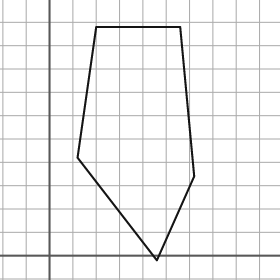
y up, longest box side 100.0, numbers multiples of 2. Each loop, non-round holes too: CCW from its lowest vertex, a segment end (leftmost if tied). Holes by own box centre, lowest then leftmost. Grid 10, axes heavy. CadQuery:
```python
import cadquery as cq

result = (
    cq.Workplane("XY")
    .moveTo(46.0, -2.0)
    .lineTo(62.0, 34.0)
    .lineTo(56.0, 98.0)
    .lineTo(20.0, 98.0)
    .lineTo(12.0, 42.0)
    .close()
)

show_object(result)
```